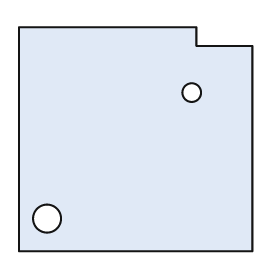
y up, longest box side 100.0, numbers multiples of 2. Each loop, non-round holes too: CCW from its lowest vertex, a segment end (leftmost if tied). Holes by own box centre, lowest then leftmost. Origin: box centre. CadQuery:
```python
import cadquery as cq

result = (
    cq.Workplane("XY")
    .moveTo(-50.0, -48.0)
    .lineTo(50.0, -48.0)
    .lineTo(50.0, 40.0)
    .lineTo(26.0, 40.0)
    .lineTo(26.0, 48.0)
    .lineTo(-50.0, 48.0)
    .close()
    .moveTo(-38.0, -34.0)
    .circle(6.0)
    .moveTo(24.0, 20.0)
    .circle(4.0)
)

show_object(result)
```